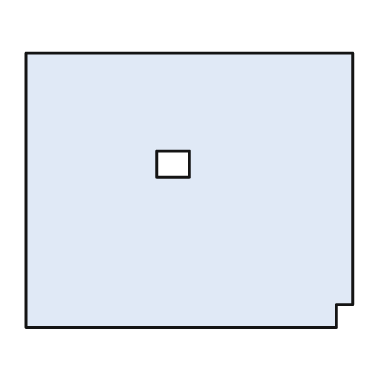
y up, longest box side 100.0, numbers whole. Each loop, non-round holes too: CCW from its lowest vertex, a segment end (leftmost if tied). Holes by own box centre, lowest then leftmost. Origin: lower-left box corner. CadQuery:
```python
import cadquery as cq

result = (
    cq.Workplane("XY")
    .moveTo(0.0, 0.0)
    .lineTo(95.0, 0.0)
    .lineTo(95.0, 7.0)
    .lineTo(100.0, 7.0)
    .lineTo(100.0, 84.0)
    .lineTo(0.0, 84.0)
    .close()
    .moveTo(40.0, 46.0)
    .lineTo(50.0, 46.0)
    .lineTo(50.0, 54.0)
    .lineTo(40.0, 54.0)
    .close()
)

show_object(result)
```